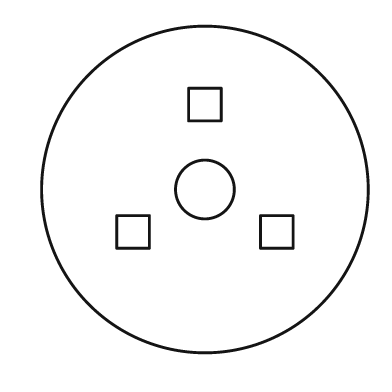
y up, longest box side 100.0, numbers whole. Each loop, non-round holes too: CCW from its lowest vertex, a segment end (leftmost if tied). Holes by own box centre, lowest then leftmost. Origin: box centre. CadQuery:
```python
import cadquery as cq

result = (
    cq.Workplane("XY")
    .moveTo(0.0, 0.0)
    .circle(50.0)
    .moveTo(-27.0, -18.0)
    .lineTo(-17.0, -18.0)
    .lineTo(-17.0, -8.0)
    .lineTo(-27.0, -8.0)
    .close()
    .moveTo(17.0, -18.0)
    .lineTo(27.0, -18.0)
    .lineTo(27.0, -8.0)
    .lineTo(17.0, -8.0)
    .close()
    .moveTo(0.0, 0.0)
    .circle(9.0)
    .moveTo(-5.0, 21.0)
    .lineTo(5.0, 21.0)
    .lineTo(5.0, 31.0)
    .lineTo(-5.0, 31.0)
    .close()
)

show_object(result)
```